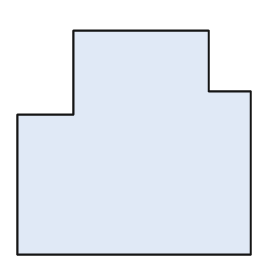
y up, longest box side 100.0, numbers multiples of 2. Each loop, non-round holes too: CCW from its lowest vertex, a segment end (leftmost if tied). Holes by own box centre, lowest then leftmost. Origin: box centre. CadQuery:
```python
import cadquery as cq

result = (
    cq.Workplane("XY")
    .moveTo(-50.0, -48.0)
    .lineTo(50.0, -48.0)
    .lineTo(50.0, 22.0)
    .lineTo(32.0, 22.0)
    .lineTo(32.0, 48.0)
    .lineTo(-26.0, 48.0)
    .lineTo(-26.0, 12.0)
    .lineTo(-50.0, 12.0)
    .close()
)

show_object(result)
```